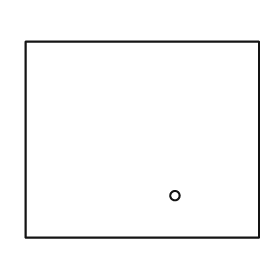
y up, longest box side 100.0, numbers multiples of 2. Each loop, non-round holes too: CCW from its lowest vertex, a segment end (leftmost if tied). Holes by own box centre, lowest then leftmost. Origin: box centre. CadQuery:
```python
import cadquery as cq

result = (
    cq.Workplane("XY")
    .moveTo(-50.0, -42.0)
    .lineTo(50.0, -42.0)
    .lineTo(50.0, 42.0)
    .lineTo(-50.0, 42.0)
    .close()
    .moveTo(14.0, -24.0)
    .circle(2.0)
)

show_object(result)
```